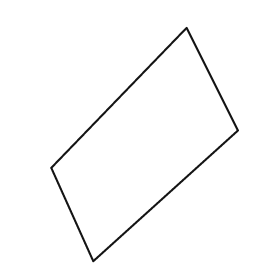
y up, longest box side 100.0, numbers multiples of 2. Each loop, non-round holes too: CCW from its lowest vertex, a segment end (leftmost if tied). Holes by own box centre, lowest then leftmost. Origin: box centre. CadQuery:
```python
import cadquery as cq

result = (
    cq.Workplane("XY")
    .moveTo(-22.0, -50.0)
    .lineTo(40.0, 6.0)
    .lineTo(18.0, 50.0)
    .lineTo(-40.0, -10.0)
    .close()
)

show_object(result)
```